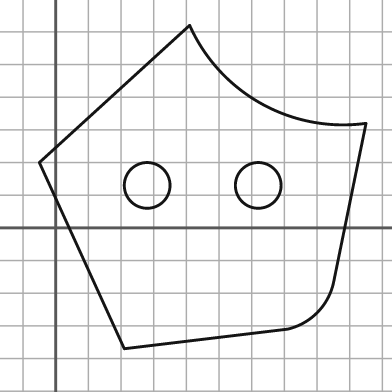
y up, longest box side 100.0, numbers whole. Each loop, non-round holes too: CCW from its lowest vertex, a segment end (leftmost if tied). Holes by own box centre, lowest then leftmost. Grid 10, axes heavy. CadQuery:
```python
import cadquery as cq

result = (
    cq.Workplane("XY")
    .moveTo(21.0, -37.0)
    .lineTo(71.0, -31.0)
    .threePointArc((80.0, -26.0), (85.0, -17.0))
    .lineTo(95.0, 32.0)
    .threePointArc((63.0, 38.0), (41.0, 62.0))
    .lineTo(-5.0, 20.0)
    .close()
    .moveTo(28.0, 13.0)
    .circle(7.0)
    .moveTo(62.0, 13.0)
    .circle(7.0)
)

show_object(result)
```